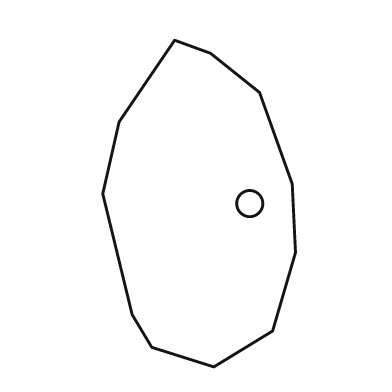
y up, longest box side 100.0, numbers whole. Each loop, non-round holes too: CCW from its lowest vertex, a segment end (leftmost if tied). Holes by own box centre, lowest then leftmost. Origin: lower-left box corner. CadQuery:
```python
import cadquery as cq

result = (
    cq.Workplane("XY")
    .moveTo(34.0, 0.0)
    .lineTo(52.0, 11.0)
    .lineTo(59.0, 35.0)
    .lineTo(58.0, 56.0)
    .lineTo(48.0, 84.0)
    .lineTo(33.0, 96.0)
    .lineTo(22.0, 100.0)
    .lineTo(5.0, 75.0)
    .lineTo(0.0, 53.0)
    .lineTo(9.0, 16.0)
    .lineTo(15.0, 6.0)
    .close()
    .moveTo(45.0, 50.0)
    .circle(4.0)
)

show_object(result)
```